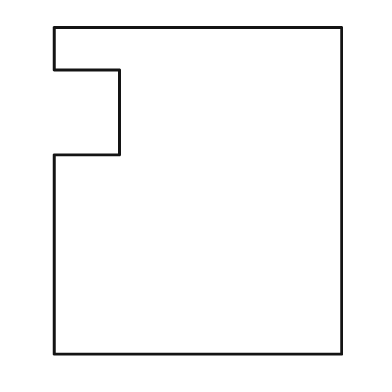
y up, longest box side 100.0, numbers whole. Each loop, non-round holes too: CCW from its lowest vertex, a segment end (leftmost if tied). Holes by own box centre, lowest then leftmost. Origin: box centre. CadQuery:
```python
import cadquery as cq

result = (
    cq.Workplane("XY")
    .moveTo(-44.0, -50.0)
    .lineTo(44.0, -50.0)
    .lineTo(44.0, 50.0)
    .lineTo(-44.0, 50.0)
    .lineTo(-44.0, 37.0)
    .lineTo(-24.0, 37.0)
    .lineTo(-24.0, 11.0)
    .lineTo(-44.0, 11.0)
    .close()
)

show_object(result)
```